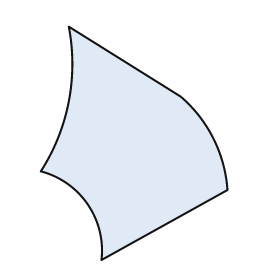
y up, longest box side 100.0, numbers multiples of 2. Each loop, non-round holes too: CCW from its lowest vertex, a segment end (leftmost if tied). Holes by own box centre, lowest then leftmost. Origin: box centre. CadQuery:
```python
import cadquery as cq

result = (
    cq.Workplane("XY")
    .moveTo(-14.0, -50.0)
    .lineTo(40.0, -20.0)
    .threePointArc((34.0, 2.0), (20.0, 20.0))
    .lineTo(-28.0, 50.0)
    .threePointArc((-28.0, 18.0), (-40.0, -12.0))
    .threePointArc((-20.0, -26.0), (-14.0, -50.0))
    .close()
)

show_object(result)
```